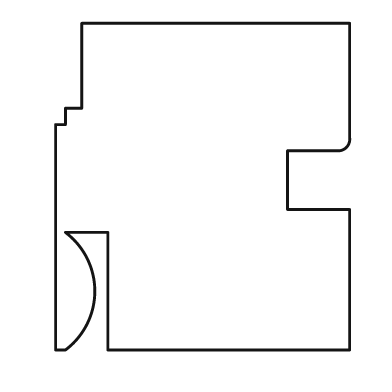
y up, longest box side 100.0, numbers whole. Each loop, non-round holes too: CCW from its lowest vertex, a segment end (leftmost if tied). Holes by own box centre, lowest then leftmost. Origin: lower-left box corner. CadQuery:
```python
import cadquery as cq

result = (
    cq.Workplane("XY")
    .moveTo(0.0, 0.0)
    .lineTo(3.0, 0.0)
    .threePointArc((12.0, 18.0), (3.0, 36.0))
    .lineTo(16.0, 36.0)
    .lineTo(16.0, 0.0)
    .lineTo(90.0, 0.0)
    .lineTo(90.0, 43.0)
    .lineTo(71.0, 43.0)
    .lineTo(71.0, 61.0)
    .lineTo(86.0, 61.0)
    .threePointArc((89.0, 62.0), (90.0, 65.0))
    .lineTo(90.0, 100.0)
    .lineTo(8.0, 100.0)
    .lineTo(8.0, 74.0)
    .lineTo(3.0, 74.0)
    .lineTo(3.0, 69.0)
    .lineTo(0.0, 69.0)
    .close()
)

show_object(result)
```